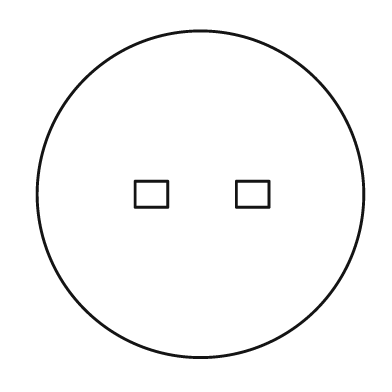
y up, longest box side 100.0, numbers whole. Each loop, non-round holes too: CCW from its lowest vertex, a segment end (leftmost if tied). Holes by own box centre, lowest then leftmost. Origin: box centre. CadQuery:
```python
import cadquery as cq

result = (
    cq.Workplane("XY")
    .moveTo(0.0, 0.0)
    .circle(50.0)
    .moveTo(-20.0, -4.0)
    .lineTo(-10.0, -4.0)
    .lineTo(-10.0, 4.0)
    .lineTo(-20.0, 4.0)
    .close()
    .moveTo(11.0, -4.0)
    .lineTo(21.0, -4.0)
    .lineTo(21.0, 4.0)
    .lineTo(11.0, 4.0)
    .close()
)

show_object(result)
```